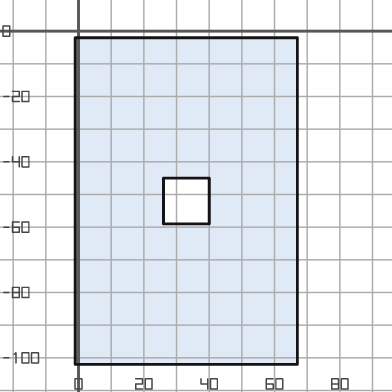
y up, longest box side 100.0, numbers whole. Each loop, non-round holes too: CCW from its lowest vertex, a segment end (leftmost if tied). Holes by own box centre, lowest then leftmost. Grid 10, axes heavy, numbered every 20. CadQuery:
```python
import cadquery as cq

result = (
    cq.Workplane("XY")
    .moveTo(-1.0, -102.0)
    .lineTo(67.0, -102.0)
    .lineTo(67.0, -2.0)
    .lineTo(-1.0, -2.0)
    .close()
    .moveTo(26.0, -59.0)
    .lineTo(40.0, -59.0)
    .lineTo(40.0, -45.0)
    .lineTo(26.0, -45.0)
    .close()
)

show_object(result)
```